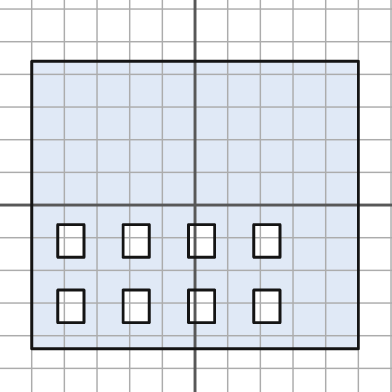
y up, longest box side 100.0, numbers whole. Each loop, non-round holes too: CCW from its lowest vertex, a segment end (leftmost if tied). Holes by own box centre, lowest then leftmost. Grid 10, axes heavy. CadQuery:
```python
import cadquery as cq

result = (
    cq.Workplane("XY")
    .moveTo(-50.0, -44.0)
    .lineTo(50.0, -44.0)
    .lineTo(50.0, 44.0)
    .lineTo(-50.0, 44.0)
    .close()
    .moveTo(-42.0, -36.0)
    .lineTo(-34.0, -36.0)
    .lineTo(-34.0, -26.0)
    .lineTo(-42.0, -26.0)
    .close()
    .moveTo(-22.0, -36.0)
    .lineTo(-14.0, -36.0)
    .lineTo(-14.0, -26.0)
    .lineTo(-22.0, -26.0)
    .close()
    .moveTo(-2.0, -36.0)
    .lineTo(6.0, -36.0)
    .lineTo(6.0, -26.0)
    .lineTo(-2.0, -26.0)
    .close()
    .moveTo(18.0, -36.0)
    .lineTo(26.0, -36.0)
    .lineTo(26.0, -26.0)
    .lineTo(18.0, -26.0)
    .close()
    .moveTo(-42.0, -16.0)
    .lineTo(-34.0, -16.0)
    .lineTo(-34.0, -6.0)
    .lineTo(-42.0, -6.0)
    .close()
    .moveTo(-22.0, -16.0)
    .lineTo(-14.0, -16.0)
    .lineTo(-14.0, -6.0)
    .lineTo(-22.0, -6.0)
    .close()
    .moveTo(-2.0, -16.0)
    .lineTo(6.0, -16.0)
    .lineTo(6.0, -6.0)
    .lineTo(-2.0, -6.0)
    .close()
    .moveTo(18.0, -16.0)
    .lineTo(26.0, -16.0)
    .lineTo(26.0, -6.0)
    .lineTo(18.0, -6.0)
    .close()
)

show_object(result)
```